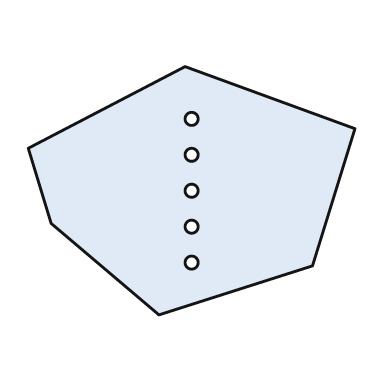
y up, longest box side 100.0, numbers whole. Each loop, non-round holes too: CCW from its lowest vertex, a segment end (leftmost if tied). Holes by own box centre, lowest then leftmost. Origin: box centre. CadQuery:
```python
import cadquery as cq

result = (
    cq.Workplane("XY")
    .moveTo(-10.0, -38.0)
    .lineTo(37.0, -23.0)
    .lineTo(50.0, 19.0)
    .lineTo(-2.0, 38.0)
    .lineTo(-50.0, 13.0)
    .lineTo(-43.0, -10.0)
    .close()
    .moveTo(0.0, -22.0)
    .circle(2.0)
    .moveTo(0.0, -11.0)
    .circle(2.0)
    .moveTo(0.0, 0.0)
    .circle(2.0)
    .moveTo(0.0, 11.0)
    .circle(2.0)
    .moveTo(0.0, 22.0)
    .circle(2.0)
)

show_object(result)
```